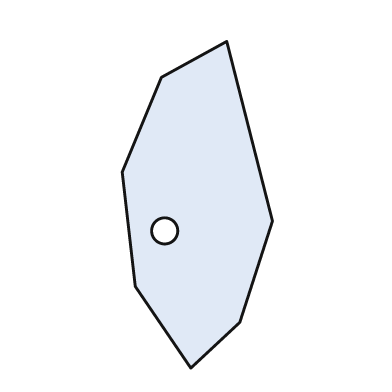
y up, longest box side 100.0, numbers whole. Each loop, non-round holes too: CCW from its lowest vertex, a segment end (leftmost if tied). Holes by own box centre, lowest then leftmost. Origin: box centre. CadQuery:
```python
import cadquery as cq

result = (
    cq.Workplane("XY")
    .moveTo(-2.0, -50.0)
    .lineTo(13.0, -36.0)
    .lineTo(23.0, -5.0)
    .lineTo(9.0, 50.0)
    .lineTo(-11.0, 39.0)
    .lineTo(-23.0, 10.0)
    .lineTo(-19.0, -25.0)
    .close()
    .moveTo(-10.0, -8.0)
    .circle(4.0)
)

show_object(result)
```